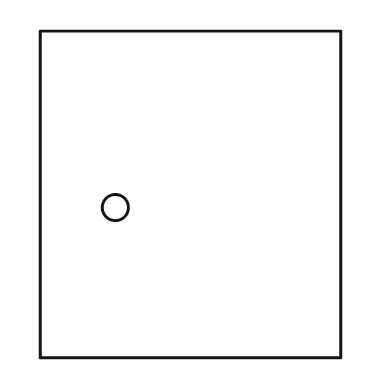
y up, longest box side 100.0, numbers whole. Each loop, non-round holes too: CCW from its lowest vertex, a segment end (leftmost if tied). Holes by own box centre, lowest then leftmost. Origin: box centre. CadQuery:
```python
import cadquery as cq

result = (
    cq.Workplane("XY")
    .moveTo(-46.0, -50.0)
    .lineTo(46.0, -50.0)
    .lineTo(46.0, 50.0)
    .lineTo(-46.0, 50.0)
    .close()
    .moveTo(-23.0, -4.0)
    .circle(4.0)
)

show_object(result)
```